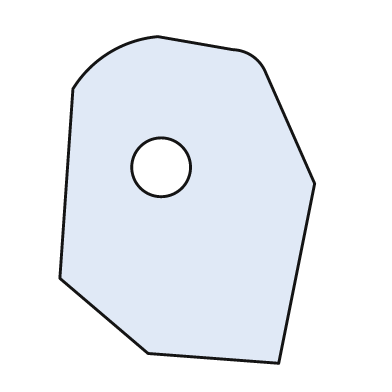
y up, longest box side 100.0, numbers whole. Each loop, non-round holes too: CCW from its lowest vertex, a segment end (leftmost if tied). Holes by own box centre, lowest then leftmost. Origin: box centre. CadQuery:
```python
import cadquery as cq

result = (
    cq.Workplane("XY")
    .moveTo(28.0, -50.0)
    .lineTo(39.0, 5.0)
    .lineTo(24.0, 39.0)
    .threePointArc((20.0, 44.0), (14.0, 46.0))
    .lineTo(-9.0, 50.0)
    .threePointArc((-24.0, 45.0), (-35.0, 34.0))
    .lineTo(-39.0, -24.0)
    .lineTo(-12.0, -47.0)
    .close()
    .moveTo(-8.0, 10.0)
    .circle(9.0)
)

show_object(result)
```